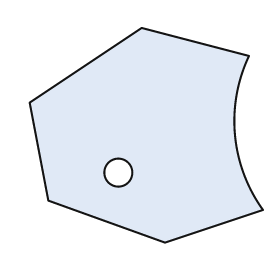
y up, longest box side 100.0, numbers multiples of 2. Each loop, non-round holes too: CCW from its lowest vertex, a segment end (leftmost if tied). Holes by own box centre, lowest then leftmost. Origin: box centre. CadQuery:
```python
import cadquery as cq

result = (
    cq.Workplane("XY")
    .moveTo(8.0, -46.0)
    .lineTo(50.0, -32.0)
    .threePointArc((38.0, 0.0), (44.0, 34.0))
    .lineTo(-2.0, 46.0)
    .lineTo(-50.0, 14.0)
    .lineTo(-42.0, -28.0)
    .close()
    .moveTo(-12.0, -16.0)
    .circle(6.0)
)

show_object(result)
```